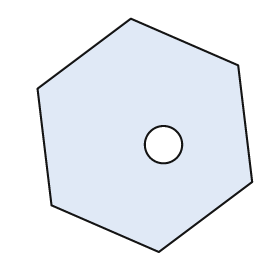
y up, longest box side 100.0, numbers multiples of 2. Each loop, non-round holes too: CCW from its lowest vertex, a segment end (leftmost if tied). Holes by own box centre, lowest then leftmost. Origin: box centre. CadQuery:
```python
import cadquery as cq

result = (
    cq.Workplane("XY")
    .moveTo(6.0, -50.0)
    .lineTo(46.0, -20.0)
    .lineTo(40.0, 30.0)
    .lineTo(-6.0, 50.0)
    .lineTo(-46.0, 20.0)
    .lineTo(-40.0, -30.0)
    .close()
    .moveTo(8.0, -4.0)
    .circle(8.0)
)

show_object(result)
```